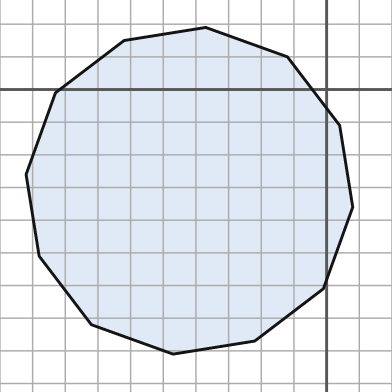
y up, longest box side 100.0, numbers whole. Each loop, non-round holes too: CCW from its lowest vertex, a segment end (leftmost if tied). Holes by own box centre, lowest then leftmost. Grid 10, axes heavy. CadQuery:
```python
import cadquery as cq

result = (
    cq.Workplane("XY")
    .moveTo(-47.0, -81.0)
    .lineTo(-22.0, -77.0)
    .lineTo(-1.0, -61.0)
    .lineTo(8.0, -36.0)
    .lineTo(4.0, -11.0)
    .lineTo(-12.0, 10.0)
    .lineTo(-37.0, 19.0)
    .lineTo(-62.0, 15.0)
    .lineTo(-83.0, -1.0)
    .lineTo(-92.0, -26.0)
    .lineTo(-88.0, -51.0)
    .lineTo(-72.0, -72.0)
    .close()
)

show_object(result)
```